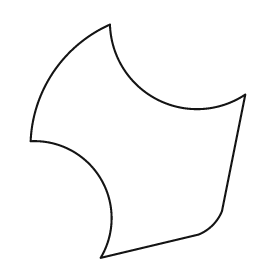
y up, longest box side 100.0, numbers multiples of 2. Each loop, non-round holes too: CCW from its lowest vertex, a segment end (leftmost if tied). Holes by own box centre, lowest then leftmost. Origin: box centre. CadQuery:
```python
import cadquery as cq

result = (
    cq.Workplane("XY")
    .moveTo(-16.0, -50.0)
    .lineTo(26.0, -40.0)
    .threePointArc((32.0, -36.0), (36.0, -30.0))
    .lineTo(46.0, 20.0)
    .threePointArc((8.0, 18.0), (-12.0, 50.0))
    .threePointArc((-36.0, 30.0), (-46.0, 0.0))
    .threePointArc((-16.0, -16.0), (-16.0, -50.0))
    .close()
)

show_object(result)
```